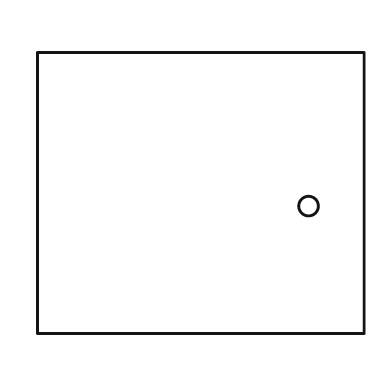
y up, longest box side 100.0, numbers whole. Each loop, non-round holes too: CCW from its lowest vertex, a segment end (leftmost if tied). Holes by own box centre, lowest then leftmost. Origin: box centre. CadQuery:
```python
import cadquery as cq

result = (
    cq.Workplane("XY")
    .moveTo(-50.0, -43.0)
    .lineTo(50.0, -43.0)
    .lineTo(50.0, 43.0)
    .lineTo(-50.0, 43.0)
    .close()
    .moveTo(33.0, -4.0)
    .circle(3.0)
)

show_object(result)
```